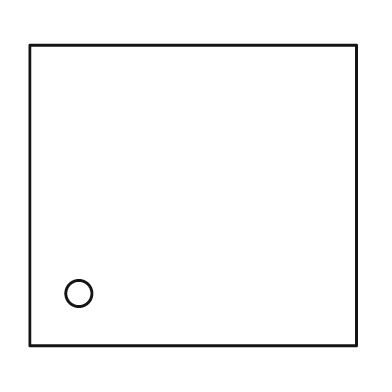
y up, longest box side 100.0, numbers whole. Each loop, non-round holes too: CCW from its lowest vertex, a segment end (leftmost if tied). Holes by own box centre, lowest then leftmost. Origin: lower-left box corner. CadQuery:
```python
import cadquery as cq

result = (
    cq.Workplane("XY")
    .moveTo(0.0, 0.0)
    .lineTo(100.0, 0.0)
    .lineTo(100.0, 92.0)
    .lineTo(0.0, 92.0)
    .close()
    .moveTo(15.0, 16.0)
    .circle(4.0)
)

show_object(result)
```